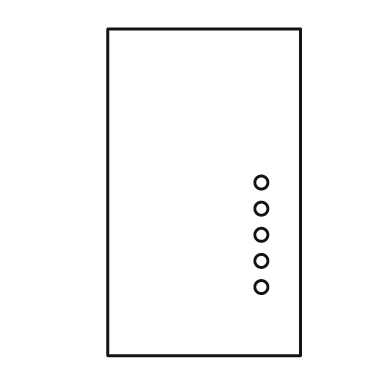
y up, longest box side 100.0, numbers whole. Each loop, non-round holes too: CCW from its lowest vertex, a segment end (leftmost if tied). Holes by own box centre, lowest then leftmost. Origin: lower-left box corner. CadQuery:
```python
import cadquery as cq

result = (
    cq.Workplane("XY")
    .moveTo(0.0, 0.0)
    .lineTo(59.0, 0.0)
    .lineTo(59.0, 100.0)
    .lineTo(0.0, 100.0)
    .close()
    .moveTo(47.0, 21.0)
    .circle(2.0)
    .moveTo(47.0, 29.0)
    .circle(2.0)
    .moveTo(47.0, 37.0)
    .circle(2.0)
    .moveTo(47.0, 45.0)
    .circle(2.0)
    .moveTo(47.0, 53.0)
    .circle(2.0)
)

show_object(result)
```